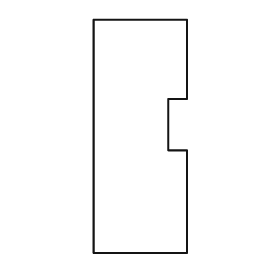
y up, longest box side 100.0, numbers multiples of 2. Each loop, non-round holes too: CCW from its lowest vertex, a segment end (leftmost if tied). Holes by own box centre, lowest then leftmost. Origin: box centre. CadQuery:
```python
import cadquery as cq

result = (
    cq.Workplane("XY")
    .moveTo(-20.0, -50.0)
    .lineTo(20.0, -50.0)
    .lineTo(20.0, -6.0)
    .lineTo(12.0, -6.0)
    .lineTo(12.0, 16.0)
    .lineTo(20.0, 16.0)
    .lineTo(20.0, 50.0)
    .lineTo(-20.0, 50.0)
    .close()
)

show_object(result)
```